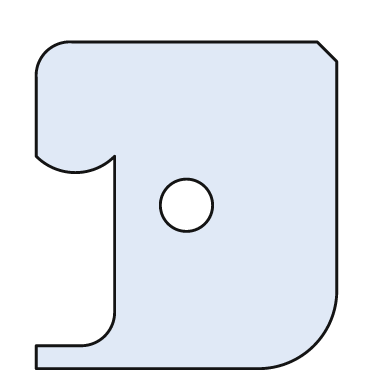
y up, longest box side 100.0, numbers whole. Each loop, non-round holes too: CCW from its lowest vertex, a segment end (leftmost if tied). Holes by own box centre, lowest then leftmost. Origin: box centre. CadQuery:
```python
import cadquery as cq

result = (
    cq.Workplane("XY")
    .moveTo(-46.0, -50.0)
    .lineTo(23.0, -50.0)
    .threePointArc((39.0, -43.0), (46.0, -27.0))
    .lineTo(46.0, 44.0)
    .lineTo(40.0, 50.0)
    .lineTo(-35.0, 50.0)
    .threePointArc((-43.0, 47.0), (-46.0, 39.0))
    .lineTo(-46.0, 15.0)
    .threePointArc((-34.0, 10.0), (-22.0, 15.0))
    .lineTo(-22.0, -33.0)
    .threePointArc((-25.0, -40.0), (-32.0, -43.0))
    .lineTo(-46.0, -43.0)
    .close()
    .moveTo(0.0, 0.0)
    .circle(8.0)
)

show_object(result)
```